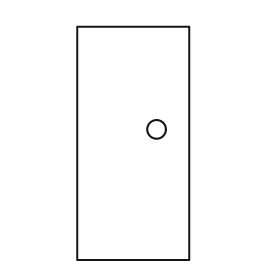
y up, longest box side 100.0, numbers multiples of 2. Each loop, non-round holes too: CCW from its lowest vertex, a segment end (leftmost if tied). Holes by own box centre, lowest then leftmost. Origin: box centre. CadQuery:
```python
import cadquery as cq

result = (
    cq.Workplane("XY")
    .moveTo(-24.0, -50.0)
    .lineTo(24.0, -50.0)
    .lineTo(24.0, 50.0)
    .lineTo(-24.0, 50.0)
    .close()
    .moveTo(10.0, 6.0)
    .circle(4.0)
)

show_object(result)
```